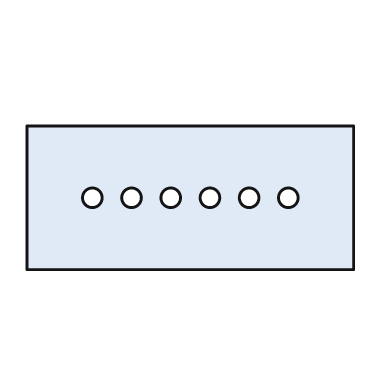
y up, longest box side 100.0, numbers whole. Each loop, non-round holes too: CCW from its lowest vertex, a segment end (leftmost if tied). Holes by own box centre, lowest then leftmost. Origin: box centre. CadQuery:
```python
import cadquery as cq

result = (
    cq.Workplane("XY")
    .moveTo(-50.0, -22.0)
    .lineTo(50.0, -22.0)
    .lineTo(50.0, 22.0)
    .lineTo(-50.0, 22.0)
    .close()
    .moveTo(-30.0, 0.0)
    .circle(3.0)
    .moveTo(-18.0, 0.0)
    .circle(3.0)
    .moveTo(-6.0, 0.0)
    .circle(3.0)
    .moveTo(6.0, 0.0)
    .circle(3.0)
    .moveTo(18.0, 0.0)
    .circle(3.0)
    .moveTo(30.0, 0.0)
    .circle(3.0)
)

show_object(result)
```